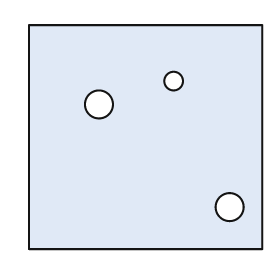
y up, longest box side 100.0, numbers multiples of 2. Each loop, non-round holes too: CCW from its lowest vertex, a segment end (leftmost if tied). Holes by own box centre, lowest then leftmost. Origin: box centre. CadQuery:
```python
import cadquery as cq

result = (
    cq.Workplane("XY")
    .moveTo(-50.0, -48.0)
    .lineTo(50.0, -48.0)
    .lineTo(50.0, 48.0)
    .lineTo(-50.0, 48.0)
    .close()
    .moveTo(36.0, -30.0)
    .circle(6.0)
    .moveTo(-20.0, 14.0)
    .circle(6.0)
    .moveTo(12.0, 24.0)
    .circle(4.0)
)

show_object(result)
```